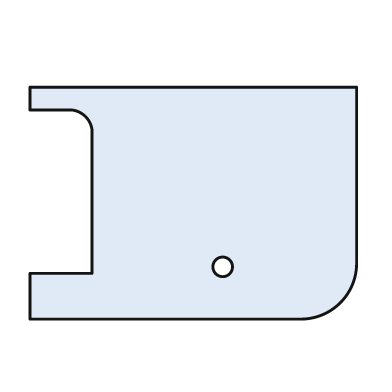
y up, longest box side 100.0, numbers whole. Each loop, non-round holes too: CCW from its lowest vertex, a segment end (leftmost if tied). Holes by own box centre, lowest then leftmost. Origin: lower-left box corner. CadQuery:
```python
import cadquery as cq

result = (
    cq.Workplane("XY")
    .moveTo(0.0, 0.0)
    .lineTo(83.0, 0.0)
    .threePointArc((95.0, 5.0), (100.0, 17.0))
    .lineTo(100.0, 71.0)
    .lineTo(0.0, 71.0)
    .lineTo(0.0, 64.0)
    .lineTo(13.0, 64.0)
    .threePointArc((17.0, 62.0), (19.0, 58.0))
    .lineTo(19.0, 14.0)
    .lineTo(0.0, 14.0)
    .close()
    .moveTo(59.0, 16.0)
    .circle(3.0)
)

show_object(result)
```